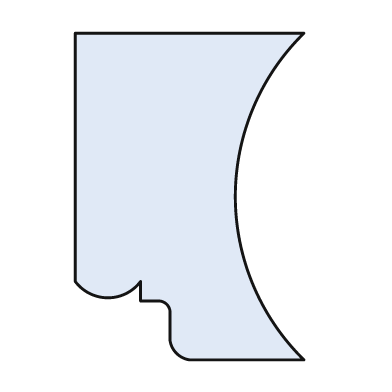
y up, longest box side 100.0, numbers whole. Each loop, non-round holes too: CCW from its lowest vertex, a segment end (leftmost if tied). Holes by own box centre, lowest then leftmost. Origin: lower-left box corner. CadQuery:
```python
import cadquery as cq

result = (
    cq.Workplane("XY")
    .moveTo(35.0, 0.0)
    .lineTo(70.0, 0.0)
    .threePointArc((49.0, 50.0), (70.0, 100.0))
    .lineTo(0.0, 100.0)
    .lineTo(0.0, 24.0)
    .threePointArc((10.0, 19.0), (20.0, 24.0))
    .lineTo(20.0, 18.0)
    .lineTo(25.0, 18.0)
    .threePointArc((28.0, 17.0), (29.0, 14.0))
    .lineTo(29.0, 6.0)
    .threePointArc((31.0, 2.0), (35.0, 0.0))
    .close()
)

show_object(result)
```